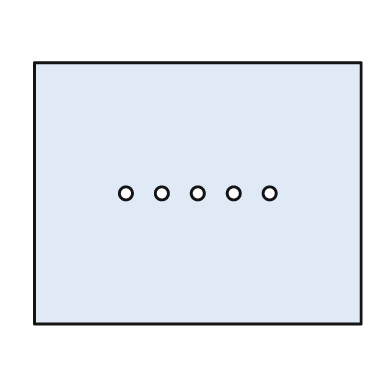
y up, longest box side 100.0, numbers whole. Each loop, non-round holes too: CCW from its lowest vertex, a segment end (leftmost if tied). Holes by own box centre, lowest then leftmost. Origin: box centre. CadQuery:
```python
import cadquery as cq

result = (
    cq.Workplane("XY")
    .moveTo(-50.0, -40.0)
    .lineTo(50.0, -40.0)
    .lineTo(50.0, 40.0)
    .lineTo(-50.0, 40.0)
    .close()
    .moveTo(-22.0, 0.0)
    .circle(2.0)
    .moveTo(-11.0, 0.0)
    .circle(2.0)
    .moveTo(0.0, 0.0)
    .circle(2.0)
    .moveTo(11.0, 0.0)
    .circle(2.0)
    .moveTo(22.0, 0.0)
    .circle(2.0)
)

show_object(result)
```